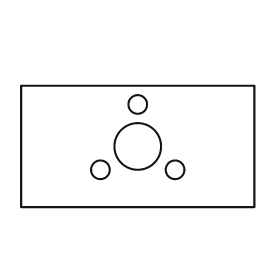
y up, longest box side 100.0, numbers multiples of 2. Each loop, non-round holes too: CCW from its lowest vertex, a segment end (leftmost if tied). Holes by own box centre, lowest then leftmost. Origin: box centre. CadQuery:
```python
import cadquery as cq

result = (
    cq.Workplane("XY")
    .moveTo(-50.0, -26.0)
    .lineTo(50.0, -26.0)
    .lineTo(50.0, 26.0)
    .lineTo(-50.0, 26.0)
    .close()
    .moveTo(-16.0, -10.0)
    .circle(4.0)
    .moveTo(16.0, -10.0)
    .circle(4.0)
    .moveTo(0.0, 0.0)
    .circle(10.0)
    .moveTo(0.0, 18.0)
    .circle(4.0)
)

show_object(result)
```